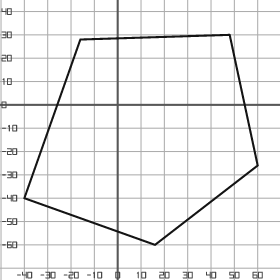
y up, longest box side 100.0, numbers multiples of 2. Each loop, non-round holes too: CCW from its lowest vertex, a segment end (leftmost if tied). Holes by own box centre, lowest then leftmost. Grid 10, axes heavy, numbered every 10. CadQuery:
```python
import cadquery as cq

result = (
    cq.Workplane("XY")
    .moveTo(16.0, -60.0)
    .lineTo(60.0, -26.0)
    .lineTo(48.0, 30.0)
    .lineTo(-16.0, 28.0)
    .lineTo(-40.0, -40.0)
    .close()
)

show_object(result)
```